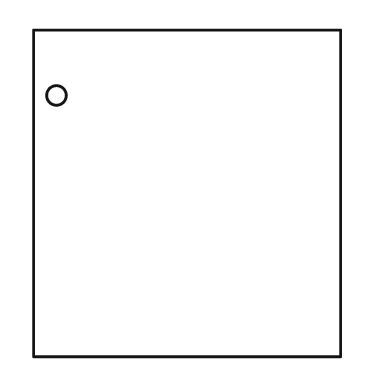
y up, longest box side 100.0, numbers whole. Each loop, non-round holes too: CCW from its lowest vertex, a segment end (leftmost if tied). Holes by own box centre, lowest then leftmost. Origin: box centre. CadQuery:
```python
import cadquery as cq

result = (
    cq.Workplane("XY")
    .moveTo(-47.0, -50.0)
    .lineTo(47.0, -50.0)
    .lineTo(47.0, 50.0)
    .lineTo(-47.0, 50.0)
    .close()
    .moveTo(-40.0, 30.0)
    .circle(3.0)
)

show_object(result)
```